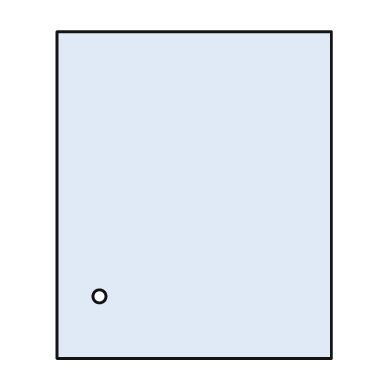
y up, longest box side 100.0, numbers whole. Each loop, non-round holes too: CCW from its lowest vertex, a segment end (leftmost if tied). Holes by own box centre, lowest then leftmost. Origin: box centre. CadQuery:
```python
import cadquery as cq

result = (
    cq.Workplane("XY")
    .moveTo(-42.0, -50.0)
    .lineTo(42.0, -50.0)
    .lineTo(42.0, 50.0)
    .lineTo(-42.0, 50.0)
    .close()
    .moveTo(-29.0, -31.0)
    .circle(2.0)
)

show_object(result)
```